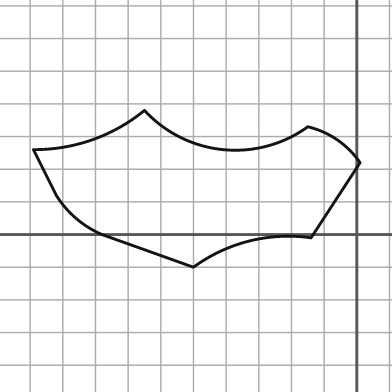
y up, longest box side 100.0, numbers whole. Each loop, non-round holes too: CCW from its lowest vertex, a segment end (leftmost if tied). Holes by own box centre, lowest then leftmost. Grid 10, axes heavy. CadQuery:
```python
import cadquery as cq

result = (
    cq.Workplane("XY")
    .moveTo(-50.0, -10.0)
    .threePointArc((-33.0, -2.0), (-14.0, -1.0))
    .lineTo(1.0, 22.0)
    .threePointArc((-6.0, 29.0), (-15.0, 33.0))
    .threePointArc((-41.0, 26.0), (-65.0, 38.0))
    .threePointArc((-81.0, 29.0), (-99.0, 26.0))
    .lineTo(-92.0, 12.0)
    .threePointArc((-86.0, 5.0), (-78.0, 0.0))
    .close()
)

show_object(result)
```